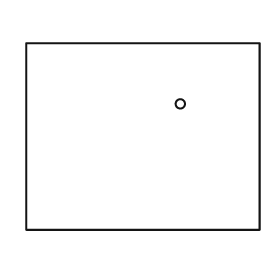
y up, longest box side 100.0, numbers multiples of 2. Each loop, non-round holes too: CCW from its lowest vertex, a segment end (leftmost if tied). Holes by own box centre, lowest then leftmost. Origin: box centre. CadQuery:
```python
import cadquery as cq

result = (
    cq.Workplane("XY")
    .moveTo(-50.0, -40.0)
    .lineTo(50.0, -40.0)
    .lineTo(50.0, 40.0)
    .lineTo(-50.0, 40.0)
    .close()
    .moveTo(16.0, 14.0)
    .circle(2.0)
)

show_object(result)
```